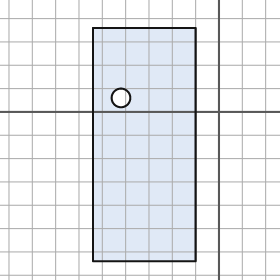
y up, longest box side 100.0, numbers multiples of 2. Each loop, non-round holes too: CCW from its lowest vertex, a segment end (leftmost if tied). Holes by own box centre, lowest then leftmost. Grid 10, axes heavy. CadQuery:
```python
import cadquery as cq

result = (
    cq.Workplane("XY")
    .moveTo(-54.0, -64.0)
    .lineTo(-10.0, -64.0)
    .lineTo(-10.0, 36.0)
    .lineTo(-54.0, 36.0)
    .close()
    .moveTo(-42.0, 6.0)
    .circle(4.0)
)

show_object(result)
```